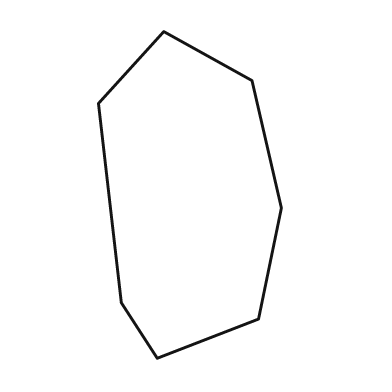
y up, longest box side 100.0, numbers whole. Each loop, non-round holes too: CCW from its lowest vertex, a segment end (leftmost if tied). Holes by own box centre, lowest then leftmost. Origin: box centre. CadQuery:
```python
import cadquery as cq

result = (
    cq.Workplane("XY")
    .moveTo(-10.0, -50.0)
    .lineTo(21.0, -38.0)
    .lineTo(28.0, -4.0)
    .lineTo(19.0, 35.0)
    .lineTo(-8.0, 50.0)
    .lineTo(-28.0, 28.0)
    .lineTo(-21.0, -33.0)
    .close()
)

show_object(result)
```